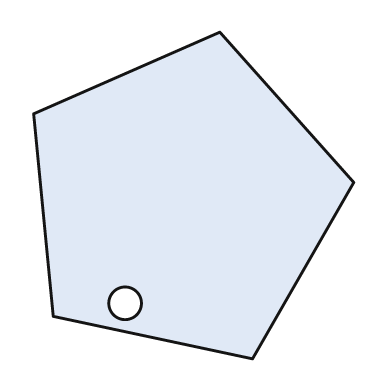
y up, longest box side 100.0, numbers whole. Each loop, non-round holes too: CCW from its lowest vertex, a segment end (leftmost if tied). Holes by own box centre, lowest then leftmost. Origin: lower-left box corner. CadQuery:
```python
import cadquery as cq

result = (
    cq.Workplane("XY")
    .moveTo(67.0, 0.0)
    .lineTo(98.0, 54.0)
    .lineTo(57.0, 100.0)
    .lineTo(0.0, 75.0)
    .lineTo(6.0, 13.0)
    .close()
    .moveTo(28.0, 17.0)
    .circle(5.0)
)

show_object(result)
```